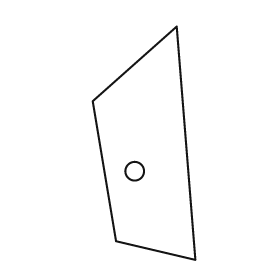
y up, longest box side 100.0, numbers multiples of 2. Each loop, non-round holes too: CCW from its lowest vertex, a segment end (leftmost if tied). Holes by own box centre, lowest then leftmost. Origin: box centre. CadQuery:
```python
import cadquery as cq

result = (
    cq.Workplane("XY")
    .moveTo(22.0, -50.0)
    .lineTo(14.0, 50.0)
    .lineTo(-22.0, 18.0)
    .lineTo(-12.0, -42.0)
    .close()
    .moveTo(-4.0, -12.0)
    .circle(4.0)
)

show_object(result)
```